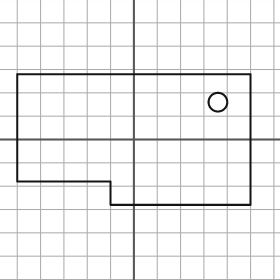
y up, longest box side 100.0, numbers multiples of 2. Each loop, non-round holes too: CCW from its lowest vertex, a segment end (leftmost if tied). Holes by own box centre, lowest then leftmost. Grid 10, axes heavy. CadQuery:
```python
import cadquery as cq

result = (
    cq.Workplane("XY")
    .moveTo(-10.0, -28.0)
    .lineTo(50.0, -28.0)
    .lineTo(50.0, 28.0)
    .lineTo(-50.0, 28.0)
    .lineTo(-50.0, -18.0)
    .lineTo(-10.0, -18.0)
    .close()
    .moveTo(36.0, 16.0)
    .circle(4.0)
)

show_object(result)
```